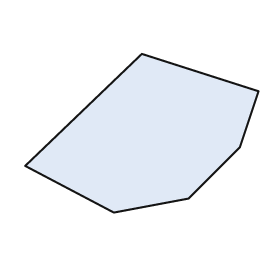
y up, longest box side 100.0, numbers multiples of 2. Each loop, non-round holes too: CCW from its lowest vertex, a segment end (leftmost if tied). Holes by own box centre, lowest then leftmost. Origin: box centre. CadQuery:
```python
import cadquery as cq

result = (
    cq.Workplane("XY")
    .moveTo(-12.0, -34.0)
    .lineTo(20.0, -28.0)
    .lineTo(42.0, -6.0)
    .lineTo(50.0, 18.0)
    .lineTo(0.0, 34.0)
    .lineTo(-50.0, -14.0)
    .close()
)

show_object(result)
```